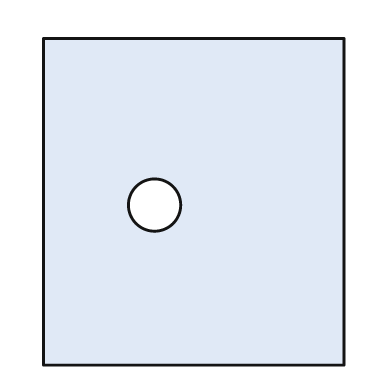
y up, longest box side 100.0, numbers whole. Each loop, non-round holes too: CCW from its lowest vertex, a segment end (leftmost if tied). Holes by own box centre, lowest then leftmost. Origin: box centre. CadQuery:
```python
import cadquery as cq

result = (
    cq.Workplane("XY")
    .moveTo(-46.0, -50.0)
    .lineTo(46.0, -50.0)
    .lineTo(46.0, 50.0)
    .lineTo(-46.0, 50.0)
    .close()
    .moveTo(-12.0, -1.0)
    .circle(8.0)
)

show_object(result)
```